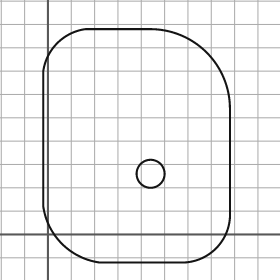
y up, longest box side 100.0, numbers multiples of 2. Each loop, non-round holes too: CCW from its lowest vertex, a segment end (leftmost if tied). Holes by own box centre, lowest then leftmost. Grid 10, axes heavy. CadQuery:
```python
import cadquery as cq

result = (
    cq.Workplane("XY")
    .moveTo(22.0, -12.0)
    .lineTo(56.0, -12.0)
    .threePointArc((72.0, -6.0), (78.0, 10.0))
    .lineTo(78.0, 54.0)
    .threePointArc((68.0, 78.0), (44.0, 88.0))
    .lineTo(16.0, 88.0)
    .threePointArc((4.0, 82.0), (-2.0, 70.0))
    .lineTo(-2.0, 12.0)
    .threePointArc((6.0, -4.0), (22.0, -12.0))
    .close()
    .moveTo(44.0, 26.0)
    .circle(6.0)
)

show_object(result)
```